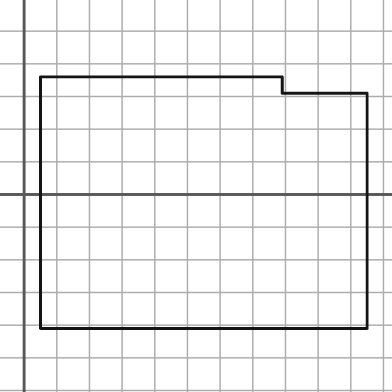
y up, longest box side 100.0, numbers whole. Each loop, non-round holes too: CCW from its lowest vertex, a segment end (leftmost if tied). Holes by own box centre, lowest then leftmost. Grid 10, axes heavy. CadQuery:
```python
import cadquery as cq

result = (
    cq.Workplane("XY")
    .moveTo(5.0, -41.0)
    .lineTo(105.0, -41.0)
    .lineTo(105.0, 31.0)
    .lineTo(79.0, 31.0)
    .lineTo(79.0, 36.0)
    .lineTo(5.0, 36.0)
    .close()
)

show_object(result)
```